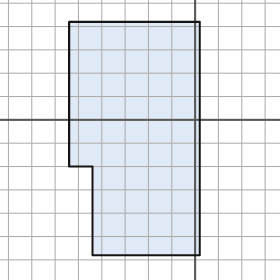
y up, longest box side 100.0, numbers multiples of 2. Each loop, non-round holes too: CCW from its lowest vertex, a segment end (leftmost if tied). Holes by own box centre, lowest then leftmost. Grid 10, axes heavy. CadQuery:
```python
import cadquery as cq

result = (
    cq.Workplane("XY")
    .moveTo(-44.0, -58.0)
    .lineTo(2.0, -58.0)
    .lineTo(2.0, 42.0)
    .lineTo(-54.0, 42.0)
    .lineTo(-54.0, -20.0)
    .lineTo(-44.0, -20.0)
    .close()
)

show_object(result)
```